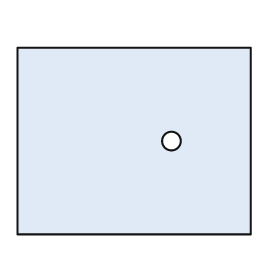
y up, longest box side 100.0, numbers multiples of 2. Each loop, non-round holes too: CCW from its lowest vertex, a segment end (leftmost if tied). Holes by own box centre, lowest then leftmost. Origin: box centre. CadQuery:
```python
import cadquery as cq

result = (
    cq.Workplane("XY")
    .moveTo(-50.0, -40.0)
    .lineTo(50.0, -40.0)
    .lineTo(50.0, 40.0)
    .lineTo(-50.0, 40.0)
    .close()
    .moveTo(16.0, 0.0)
    .circle(4.0)
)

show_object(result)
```